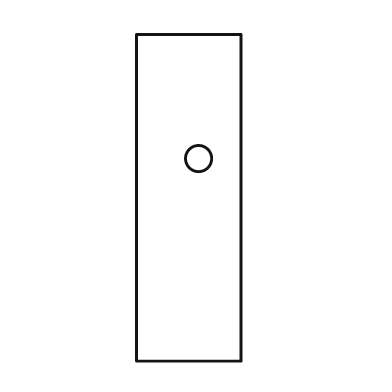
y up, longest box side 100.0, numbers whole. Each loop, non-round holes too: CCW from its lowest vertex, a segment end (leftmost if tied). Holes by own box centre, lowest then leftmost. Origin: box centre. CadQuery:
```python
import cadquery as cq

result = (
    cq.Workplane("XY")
    .moveTo(-16.0, -50.0)
    .lineTo(16.0, -50.0)
    .lineTo(16.0, 50.0)
    .lineTo(-16.0, 50.0)
    .close()
    .moveTo(3.0, 12.0)
    .circle(4.0)
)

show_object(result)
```